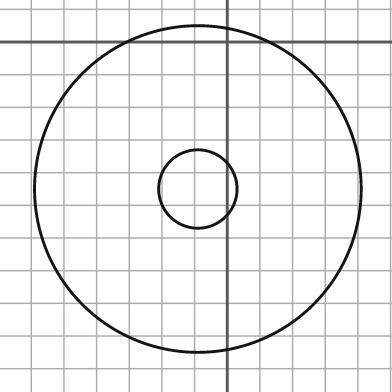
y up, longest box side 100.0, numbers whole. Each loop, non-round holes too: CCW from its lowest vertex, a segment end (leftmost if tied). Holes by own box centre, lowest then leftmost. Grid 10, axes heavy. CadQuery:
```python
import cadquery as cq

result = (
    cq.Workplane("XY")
    .moveTo(-9.0, -45.0)
    .circle(50.0)
    .moveTo(-9.0, -45.0)
    .circle(12.0)
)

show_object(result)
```